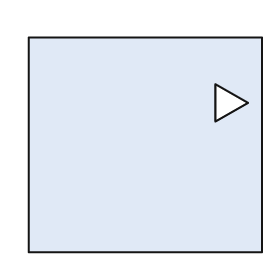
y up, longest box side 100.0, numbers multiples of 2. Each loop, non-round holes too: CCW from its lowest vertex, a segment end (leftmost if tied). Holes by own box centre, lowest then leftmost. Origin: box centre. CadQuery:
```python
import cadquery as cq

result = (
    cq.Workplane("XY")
    .moveTo(-50.0, -46.0)
    .lineTo(50.0, -46.0)
    .lineTo(50.0, 46.0)
    .lineTo(-50.0, 46.0)
    .close()
    .moveTo(30.0, 10.0)
    .lineTo(44.0, 18.0)
    .lineTo(30.0, 26.0)
    .close()
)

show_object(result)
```